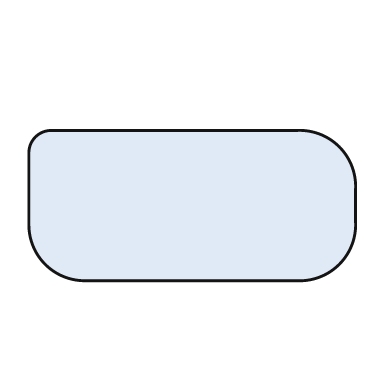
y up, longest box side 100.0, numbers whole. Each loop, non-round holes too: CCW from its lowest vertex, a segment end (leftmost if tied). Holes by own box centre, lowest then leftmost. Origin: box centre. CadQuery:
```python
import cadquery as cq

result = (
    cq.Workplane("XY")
    .moveTo(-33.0, -23.0)
    .lineTo(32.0, -23.0)
    .threePointArc((45.0, -18.0), (50.0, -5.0))
    .lineTo(50.0, 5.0)
    .threePointArc((45.0, 18.0), (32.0, 23.0))
    .lineTo(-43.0, 23.0)
    .threePointArc((-48.0, 21.0), (-50.0, 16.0))
    .lineTo(-50.0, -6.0)
    .threePointArc((-45.0, -18.0), (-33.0, -23.0))
    .close()
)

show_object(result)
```